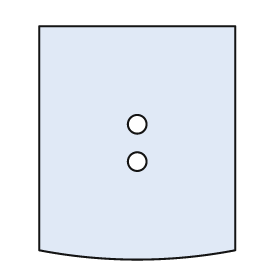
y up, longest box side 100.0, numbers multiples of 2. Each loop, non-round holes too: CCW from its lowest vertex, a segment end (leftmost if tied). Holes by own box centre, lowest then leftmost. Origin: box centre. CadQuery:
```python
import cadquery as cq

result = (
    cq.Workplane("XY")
    .moveTo(-42.0, -46.0)
    .threePointArc((0.0, -50.0), (42.0, -46.0))
    .lineTo(42.0, 50.0)
    .lineTo(-42.0, 50.0)
    .close()
    .moveTo(0.0, -8.0)
    .circle(4.0)
    .moveTo(0.0, 8.0)
    .circle(4.0)
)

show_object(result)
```